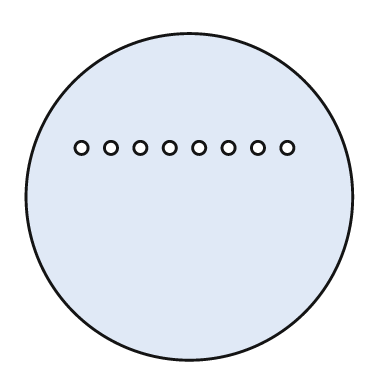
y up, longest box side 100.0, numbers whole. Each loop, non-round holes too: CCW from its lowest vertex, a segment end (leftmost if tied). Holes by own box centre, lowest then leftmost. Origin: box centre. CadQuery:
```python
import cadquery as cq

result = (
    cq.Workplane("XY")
    .moveTo(0.0, 0.0)
    .circle(50.0)
    .moveTo(-33.0, 15.0)
    .circle(2.0)
    .moveTo(-24.0, 15.0)
    .circle(2.0)
    .moveTo(-15.0, 15.0)
    .circle(2.0)
    .moveTo(-6.0, 15.0)
    .circle(2.0)
    .moveTo(3.0, 15.0)
    .circle(2.0)
    .moveTo(12.0, 15.0)
    .circle(2.0)
    .moveTo(21.0, 15.0)
    .circle(2.0)
    .moveTo(30.0, 15.0)
    .circle(2.0)
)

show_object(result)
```